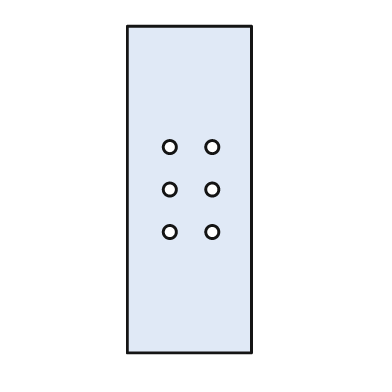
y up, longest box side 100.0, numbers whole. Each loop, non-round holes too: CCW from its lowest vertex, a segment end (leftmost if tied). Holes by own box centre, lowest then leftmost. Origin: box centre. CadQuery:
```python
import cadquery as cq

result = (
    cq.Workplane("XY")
    .moveTo(-19.0, -50.0)
    .lineTo(19.0, -50.0)
    .lineTo(19.0, 50.0)
    .lineTo(-19.0, 50.0)
    .close()
    .moveTo(-6.0, -13.0)
    .circle(2.0)
    .moveTo(7.0, -13.0)
    .circle(2.0)
    .moveTo(-6.0, 0.0)
    .circle(2.0)
    .moveTo(7.0, 0.0)
    .circle(2.0)
    .moveTo(-6.0, 13.0)
    .circle(2.0)
    .moveTo(7.0, 13.0)
    .circle(2.0)
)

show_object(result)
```